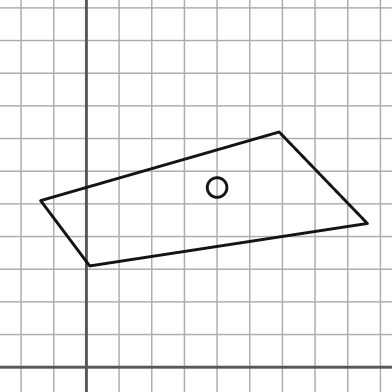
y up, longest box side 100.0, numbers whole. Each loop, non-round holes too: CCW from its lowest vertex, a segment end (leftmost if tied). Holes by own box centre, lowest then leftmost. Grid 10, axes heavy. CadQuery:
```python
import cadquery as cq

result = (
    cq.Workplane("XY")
    .moveTo(1.0, 31.0)
    .lineTo(86.0, 44.0)
    .lineTo(59.0, 72.0)
    .lineTo(-14.0, 51.0)
    .close()
    .moveTo(40.0, 55.0)
    .circle(3.0)
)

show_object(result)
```